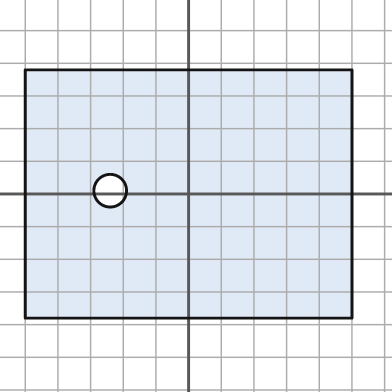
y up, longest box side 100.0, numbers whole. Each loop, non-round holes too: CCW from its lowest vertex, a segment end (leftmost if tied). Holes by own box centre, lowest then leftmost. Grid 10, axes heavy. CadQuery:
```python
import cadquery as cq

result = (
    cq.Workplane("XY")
    .moveTo(-50.0, -38.0)
    .lineTo(50.0, -38.0)
    .lineTo(50.0, 38.0)
    .lineTo(-50.0, 38.0)
    .close()
    .moveTo(-24.0, 1.0)
    .circle(5.0)
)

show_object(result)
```